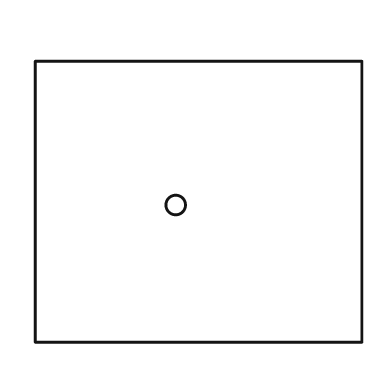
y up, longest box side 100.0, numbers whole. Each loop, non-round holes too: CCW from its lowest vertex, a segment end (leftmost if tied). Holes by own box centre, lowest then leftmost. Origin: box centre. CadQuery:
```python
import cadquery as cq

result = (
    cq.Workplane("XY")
    .moveTo(-50.0, -43.0)
    .lineTo(50.0, -43.0)
    .lineTo(50.0, 43.0)
    .lineTo(-50.0, 43.0)
    .close()
    .moveTo(-7.0, -1.0)
    .circle(3.0)
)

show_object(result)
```